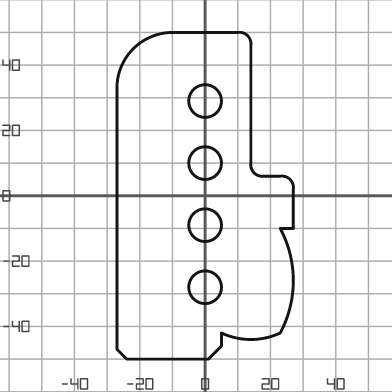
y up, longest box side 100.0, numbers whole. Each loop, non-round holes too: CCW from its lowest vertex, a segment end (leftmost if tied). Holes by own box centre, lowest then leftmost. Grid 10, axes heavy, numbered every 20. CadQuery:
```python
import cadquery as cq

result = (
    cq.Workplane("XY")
    .moveTo(-24.0, -50.0)
    .lineTo(1.0, -50.0)
    .lineTo(5.0, -46.0)
    .lineTo(5.0, -42.0)
    .threePointArc((14.0, -44.0), (23.0, -42.0))
    .threePointArc((27.0, -26.0), (23.0, -10.0))
    .lineTo(27.0, -10.0)
    .lineTo(27.0, 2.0)
    .threePointArc((26.0, 5.0), (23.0, 6.0))
    .lineTo(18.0, 6.0)
    .threePointArc((15.0, 7.0), (14.0, 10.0))
    .lineTo(14.0, 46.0)
    .threePointArc((13.0, 49.0), (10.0, 50.0))
    .lineTo(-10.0, 50.0)
    .threePointArc((-22.0, 45.0), (-27.0, 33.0))
    .lineTo(-27.0, -47.0)
    .close()
    .moveTo(0.0, -28.0)
    .circle(5.0)
    .moveTo(0.0, -9.0)
    .circle(5.0)
    .moveTo(0.0, 10.0)
    .circle(5.0)
    .moveTo(0.0, 29.0)
    .circle(5.0)
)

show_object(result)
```